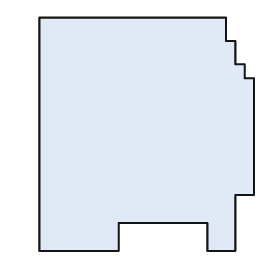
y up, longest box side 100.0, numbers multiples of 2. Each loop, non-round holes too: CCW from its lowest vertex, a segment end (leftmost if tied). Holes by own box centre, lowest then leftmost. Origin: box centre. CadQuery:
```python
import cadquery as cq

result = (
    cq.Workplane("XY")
    .moveTo(-46.0, -50.0)
    .lineTo(-12.0, -50.0)
    .lineTo(-12.0, -38.0)
    .lineTo(26.0, -38.0)
    .lineTo(26.0, -50.0)
    .lineTo(38.0, -50.0)
    .lineTo(38.0, -26.0)
    .lineTo(46.0, -26.0)
    .lineTo(46.0, 24.0)
    .lineTo(42.0, 24.0)
    .lineTo(42.0, 30.0)
    .lineTo(38.0, 30.0)
    .lineTo(38.0, 40.0)
    .lineTo(34.0, 40.0)
    .lineTo(34.0, 50.0)
    .lineTo(-46.0, 50.0)
    .close()
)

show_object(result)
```